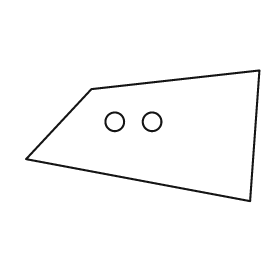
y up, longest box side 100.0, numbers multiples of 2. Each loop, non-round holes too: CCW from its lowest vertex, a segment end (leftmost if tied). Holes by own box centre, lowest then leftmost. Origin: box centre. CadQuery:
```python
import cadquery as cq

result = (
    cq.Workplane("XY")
    .moveTo(46.0, -28.0)
    .lineTo(50.0, 28.0)
    .lineTo(-22.0, 20.0)
    .lineTo(-50.0, -10.0)
    .close()
    .moveTo(-12.0, 6.0)
    .circle(4.0)
    .moveTo(4.0, 6.0)
    .circle(4.0)
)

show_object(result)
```